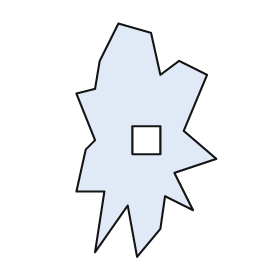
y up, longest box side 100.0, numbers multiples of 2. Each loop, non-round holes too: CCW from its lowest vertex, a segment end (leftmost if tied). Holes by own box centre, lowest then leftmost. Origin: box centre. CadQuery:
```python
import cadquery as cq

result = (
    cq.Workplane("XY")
    .moveTo(-4.0, -50.0)
    .lineTo(6.0, -38.0)
    .lineTo(8.0, -24.0)
    .lineTo(20.0, -30.0)
    .lineTo(12.0, -14.0)
    .lineTo(30.0, -8.0)
    .lineTo(16.0, 4.0)
    .lineTo(26.0, 28.0)
    .lineTo(14.0, 34.0)
    .lineTo(6.0, 28.0)
    .lineTo(2.0, 46.0)
    .lineTo(-12.0, 50.0)
    .lineTo(-20.0, 34.0)
    .lineTo(-22.0, 22.0)
    .lineTo(-30.0, 20.0)
    .lineTo(-22.0, 0.0)
    .lineTo(-26.0, -4.0)
    .lineTo(-30.0, -22.0)
    .lineTo(-18.0, -22.0)
    .lineTo(-22.0, -48.0)
    .lineTo(-8.0, -28.0)
    .close()
    .moveTo(-6.0, -6.0)
    .lineTo(6.0, -6.0)
    .lineTo(6.0, 6.0)
    .lineTo(-6.0, 6.0)
    .close()
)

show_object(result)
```